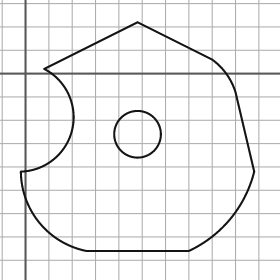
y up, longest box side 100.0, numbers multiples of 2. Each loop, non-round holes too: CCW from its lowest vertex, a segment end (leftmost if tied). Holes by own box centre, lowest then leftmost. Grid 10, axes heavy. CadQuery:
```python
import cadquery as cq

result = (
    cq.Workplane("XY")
    .moveTo(26.0, -76.0)
    .lineTo(70.0, -76.0)
    .threePointArc((88.0, -62.0), (98.0, -42.0))
    .lineTo(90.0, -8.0)
    .threePointArc((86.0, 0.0), (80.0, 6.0))
    .lineTo(48.0, 22.0)
    .lineTo(8.0, 2.0)
    .threePointArc((20.0, -24.0), (-2.0, -42.0))
    .threePointArc((6.0, -64.0), (26.0, -76.0))
    .close()
    .moveTo(48.0, -26.0)
    .circle(10.0)
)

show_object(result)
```